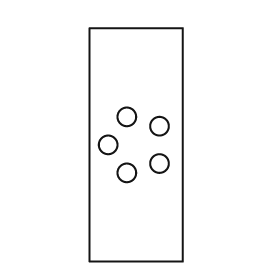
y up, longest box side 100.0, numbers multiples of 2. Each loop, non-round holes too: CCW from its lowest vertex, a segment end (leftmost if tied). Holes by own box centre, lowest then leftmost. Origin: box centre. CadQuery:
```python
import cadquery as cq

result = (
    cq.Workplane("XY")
    .moveTo(-20.0, -50.0)
    .lineTo(20.0, -50.0)
    .lineTo(20.0, 50.0)
    .lineTo(-20.0, 50.0)
    .close()
    .moveTo(-4.0, -12.0)
    .circle(4.0)
    .moveTo(10.0, -8.0)
    .circle(4.0)
    .moveTo(-12.0, 0.0)
    .circle(4.0)
    .moveTo(10.0, 8.0)
    .circle(4.0)
    .moveTo(-4.0, 12.0)
    .circle(4.0)
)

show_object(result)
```